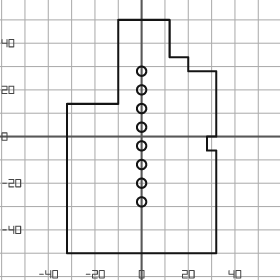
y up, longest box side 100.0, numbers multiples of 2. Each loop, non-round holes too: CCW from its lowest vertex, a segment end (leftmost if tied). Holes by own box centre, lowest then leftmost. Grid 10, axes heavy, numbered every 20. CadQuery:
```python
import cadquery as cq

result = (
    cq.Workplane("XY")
    .moveTo(-32.0, -50.0)
    .lineTo(32.0, -50.0)
    .lineTo(32.0, -6.0)
    .lineTo(28.0, -6.0)
    .lineTo(28.0, 0.0)
    .lineTo(32.0, 0.0)
    .lineTo(32.0, 28.0)
    .lineTo(20.0, 28.0)
    .lineTo(20.0, 34.0)
    .lineTo(12.0, 34.0)
    .lineTo(12.0, 50.0)
    .lineTo(-10.0, 50.0)
    .lineTo(-10.0, 14.0)
    .lineTo(-32.0, 14.0)
    .close()
    .moveTo(0.0, -28.0)
    .circle(2.0)
    .moveTo(0.0, -20.0)
    .circle(2.0)
    .moveTo(0.0, -12.0)
    .circle(2.0)
    .moveTo(0.0, -4.0)
    .circle(2.0)
    .moveTo(0.0, 4.0)
    .circle(2.0)
    .moveTo(0.0, 12.0)
    .circle(2.0)
    .moveTo(0.0, 20.0)
    .circle(2.0)
    .moveTo(0.0, 28.0)
    .circle(2.0)
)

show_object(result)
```